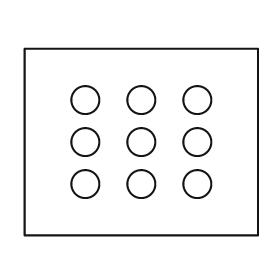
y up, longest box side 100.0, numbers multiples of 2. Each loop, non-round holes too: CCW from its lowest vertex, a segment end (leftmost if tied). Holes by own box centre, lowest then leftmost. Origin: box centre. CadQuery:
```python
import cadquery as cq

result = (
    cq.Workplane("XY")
    .moveTo(-50.0, -40.0)
    .lineTo(50.0, -40.0)
    .lineTo(50.0, 40.0)
    .lineTo(-50.0, 40.0)
    .close()
    .moveTo(-24.0, -18.0)
    .circle(6.0)
    .moveTo(0.0, -18.0)
    .circle(6.0)
    .moveTo(24.0, -18.0)
    .circle(6.0)
    .moveTo(-24.0, 0.0)
    .circle(6.0)
    .moveTo(0.0, 0.0)
    .circle(6.0)
    .moveTo(24.0, 0.0)
    .circle(6.0)
    .moveTo(-24.0, 18.0)
    .circle(6.0)
    .moveTo(0.0, 18.0)
    .circle(6.0)
    .moveTo(24.0, 18.0)
    .circle(6.0)
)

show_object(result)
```